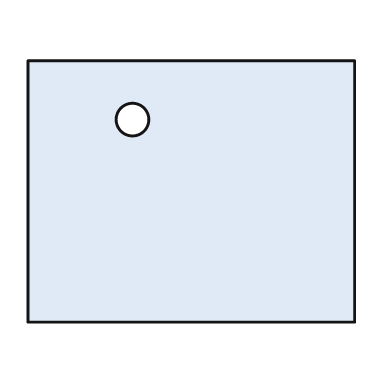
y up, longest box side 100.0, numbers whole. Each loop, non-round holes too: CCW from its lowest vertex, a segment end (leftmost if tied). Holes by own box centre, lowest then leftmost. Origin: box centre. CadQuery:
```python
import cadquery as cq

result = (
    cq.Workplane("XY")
    .moveTo(-50.0, -40.0)
    .lineTo(50.0, -40.0)
    .lineTo(50.0, 40.0)
    .lineTo(-50.0, 40.0)
    .close()
    .moveTo(-18.0, 22.0)
    .circle(5.0)
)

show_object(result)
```